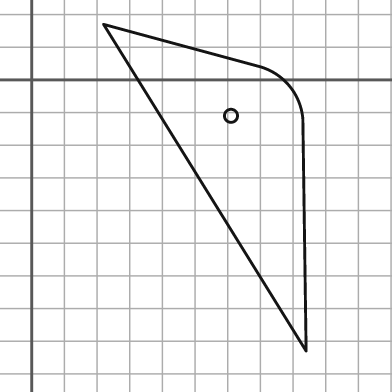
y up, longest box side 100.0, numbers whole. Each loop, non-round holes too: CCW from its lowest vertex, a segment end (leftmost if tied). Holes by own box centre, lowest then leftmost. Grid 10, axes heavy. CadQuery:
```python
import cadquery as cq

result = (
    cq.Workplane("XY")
    .moveTo(84.0, -83.0)
    .lineTo(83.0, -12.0)
    .threePointArc((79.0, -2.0), (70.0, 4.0))
    .lineTo(22.0, 17.0)
    .close()
    .moveTo(61.0, -11.0)
    .circle(2.0)
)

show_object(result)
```